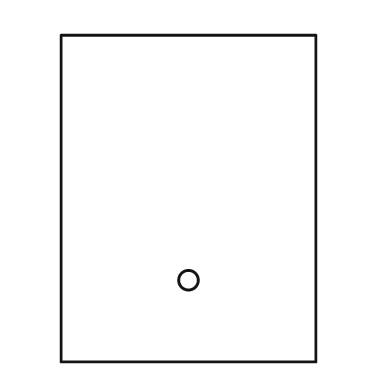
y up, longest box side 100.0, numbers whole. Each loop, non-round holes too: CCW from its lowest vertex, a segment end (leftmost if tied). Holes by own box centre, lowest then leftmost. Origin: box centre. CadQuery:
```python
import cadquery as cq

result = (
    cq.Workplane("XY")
    .moveTo(-39.0, -50.0)
    .lineTo(39.0, -50.0)
    .lineTo(39.0, 50.0)
    .lineTo(-39.0, 50.0)
    .close()
    .moveTo(0.0, -25.0)
    .circle(3.0)
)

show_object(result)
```